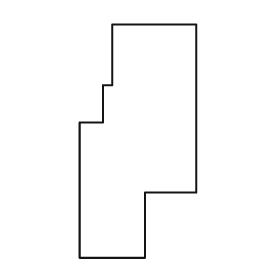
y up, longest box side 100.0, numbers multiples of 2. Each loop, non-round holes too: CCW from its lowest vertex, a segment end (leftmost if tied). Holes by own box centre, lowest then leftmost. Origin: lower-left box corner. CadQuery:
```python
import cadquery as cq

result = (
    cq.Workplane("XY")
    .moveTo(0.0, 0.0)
    .lineTo(28.0, 0.0)
    .lineTo(28.0, 28.0)
    .lineTo(50.0, 28.0)
    .lineTo(50.0, 100.0)
    .lineTo(14.0, 100.0)
    .lineTo(14.0, 74.0)
    .lineTo(10.0, 74.0)
    .lineTo(10.0, 58.0)
    .lineTo(0.0, 58.0)
    .close()
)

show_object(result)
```